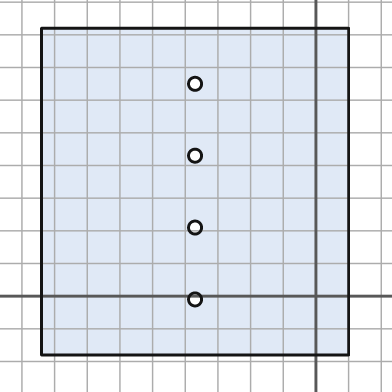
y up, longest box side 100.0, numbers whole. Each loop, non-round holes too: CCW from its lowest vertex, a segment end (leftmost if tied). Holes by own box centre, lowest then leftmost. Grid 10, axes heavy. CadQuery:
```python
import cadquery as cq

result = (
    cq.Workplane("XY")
    .moveTo(-84.0, -18.0)
    .lineTo(10.0, -18.0)
    .lineTo(10.0, 82.0)
    .lineTo(-84.0, 82.0)
    .close()
    .moveTo(-37.0, -1.0)
    .circle(2.0)
    .moveTo(-37.0, 21.0)
    .circle(2.0)
    .moveTo(-37.0, 43.0)
    .circle(2.0)
    .moveTo(-37.0, 65.0)
    .circle(2.0)
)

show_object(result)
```